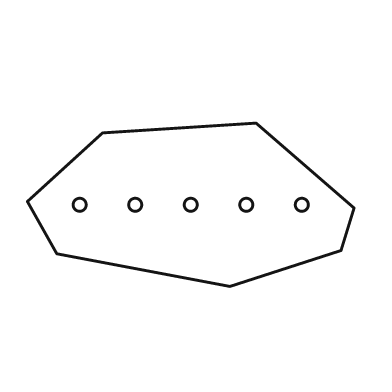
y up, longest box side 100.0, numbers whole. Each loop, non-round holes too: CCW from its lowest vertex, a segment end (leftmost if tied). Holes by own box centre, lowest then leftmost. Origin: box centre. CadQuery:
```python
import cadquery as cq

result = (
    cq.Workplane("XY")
    .moveTo(12.0, -25.0)
    .lineTo(46.0, -14.0)
    .lineTo(50.0, -1.0)
    .lineTo(20.0, 25.0)
    .lineTo(-27.0, 22.0)
    .lineTo(-50.0, 1.0)
    .lineTo(-41.0, -15.0)
    .close()
    .moveTo(-34.0, 0.0)
    .circle(2.0)
    .moveTo(-17.0, 0.0)
    .circle(2.0)
    .moveTo(0.0, 0.0)
    .circle(2.0)
    .moveTo(17.0, 0.0)
    .circle(2.0)
    .moveTo(34.0, 0.0)
    .circle(2.0)
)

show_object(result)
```